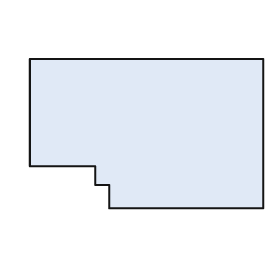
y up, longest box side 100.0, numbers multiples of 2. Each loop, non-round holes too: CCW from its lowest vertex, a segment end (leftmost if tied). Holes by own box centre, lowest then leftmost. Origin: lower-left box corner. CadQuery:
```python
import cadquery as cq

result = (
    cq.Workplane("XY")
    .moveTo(34.0, 0.0)
    .lineTo(100.0, 0.0)
    .lineTo(100.0, 64.0)
    .lineTo(0.0, 64.0)
    .lineTo(0.0, 18.0)
    .lineTo(28.0, 18.0)
    .lineTo(28.0, 10.0)
    .lineTo(34.0, 10.0)
    .close()
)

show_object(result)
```